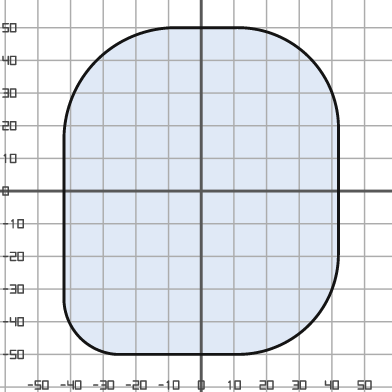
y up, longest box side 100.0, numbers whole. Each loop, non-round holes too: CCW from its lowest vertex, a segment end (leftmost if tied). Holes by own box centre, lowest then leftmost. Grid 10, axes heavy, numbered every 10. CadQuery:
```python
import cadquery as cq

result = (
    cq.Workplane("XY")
    .moveTo(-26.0, -50.0)
    .lineTo(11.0, -50.0)
    .threePointArc((33.0, -41.0), (42.0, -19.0))
    .lineTo(42.0, 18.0)
    .threePointArc((33.0, 41.0), (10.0, 50.0))
    .lineTo(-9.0, 50.0)
    .threePointArc((-32.0, 40.0), (-42.0, 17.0))
    .lineTo(-42.0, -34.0)
    .threePointArc((-37.0, -45.0), (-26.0, -50.0))
    .close()
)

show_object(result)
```